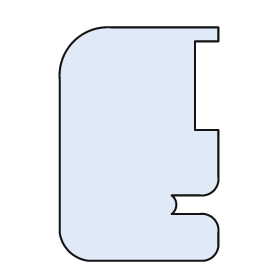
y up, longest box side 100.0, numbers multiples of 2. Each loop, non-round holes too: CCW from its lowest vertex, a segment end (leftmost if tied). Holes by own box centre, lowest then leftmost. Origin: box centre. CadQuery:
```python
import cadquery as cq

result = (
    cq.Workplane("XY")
    .moveTo(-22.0, -50.0)
    .lineTo(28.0, -50.0)
    .threePointArc((32.0, -48.0), (34.0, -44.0))
    .lineTo(34.0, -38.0)
    .threePointArc((32.0, -32.0), (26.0, -30.0))
    .lineTo(14.0, -30.0)
    .threePointArc((16.0, -26.0), (14.0, -22.0))
    .lineTo(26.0, -22.0)
    .threePointArc((32.0, -20.0), (34.0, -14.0))
    .lineTo(34.0, 6.0)
    .lineTo(24.0, 6.0)
    .lineTo(24.0, 44.0)
    .lineTo(34.0, 44.0)
    .lineTo(34.0, 50.0)
    .lineTo(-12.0, 50.0)
    .threePointArc((-28.0, 44.0), (-34.0, 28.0))
    .lineTo(-34.0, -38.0)
    .threePointArc((-30.0, -46.0), (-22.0, -50.0))
    .close()
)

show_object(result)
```